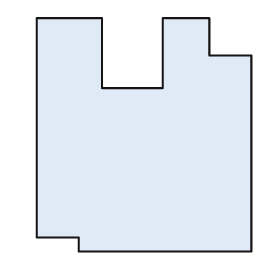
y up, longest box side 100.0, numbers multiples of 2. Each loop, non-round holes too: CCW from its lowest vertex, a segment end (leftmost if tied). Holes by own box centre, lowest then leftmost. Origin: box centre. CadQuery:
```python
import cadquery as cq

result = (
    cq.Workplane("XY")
    .moveTo(-28.0, -50.0)
    .lineTo(46.0, -50.0)
    .lineTo(46.0, 34.0)
    .lineTo(28.0, 34.0)
    .lineTo(28.0, 50.0)
    .lineTo(8.0, 50.0)
    .lineTo(8.0, 20.0)
    .lineTo(-18.0, 20.0)
    .lineTo(-18.0, 50.0)
    .lineTo(-46.0, 50.0)
    .lineTo(-46.0, -44.0)
    .lineTo(-28.0, -44.0)
    .close()
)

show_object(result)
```